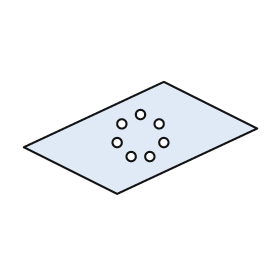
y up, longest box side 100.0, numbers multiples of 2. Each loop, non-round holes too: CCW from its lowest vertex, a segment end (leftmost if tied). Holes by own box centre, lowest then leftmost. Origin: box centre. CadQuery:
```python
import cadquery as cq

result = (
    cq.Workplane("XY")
    .moveTo(-10.0, -24.0)
    .lineTo(50.0, 4.0)
    .lineTo(10.0, 24.0)
    .lineTo(-50.0, -4.0)
    .close()
    .moveTo(-4.0, -8.0)
    .circle(2.0)
    .moveTo(4.0, -8.0)
    .circle(2.0)
    .moveTo(-10.0, -2.0)
    .circle(2.0)
    .moveTo(10.0, -2.0)
    .circle(2.0)
    .moveTo(-8.0, 6.0)
    .circle(2.0)
    .moveTo(8.0, 6.0)
    .circle(2.0)
    .moveTo(0.0, 10.0)
    .circle(2.0)
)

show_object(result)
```